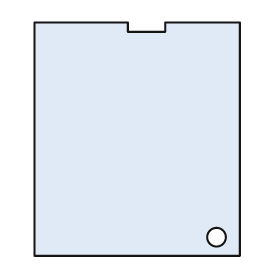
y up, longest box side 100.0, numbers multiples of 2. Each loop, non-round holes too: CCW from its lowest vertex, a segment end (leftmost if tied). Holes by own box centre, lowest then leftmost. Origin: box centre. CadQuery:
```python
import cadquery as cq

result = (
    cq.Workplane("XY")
    .moveTo(-44.0, -50.0)
    .lineTo(44.0, -50.0)
    .lineTo(44.0, 50.0)
    .lineTo(12.0, 50.0)
    .lineTo(12.0, 46.0)
    .lineTo(-4.0, 46.0)
    .lineTo(-4.0, 50.0)
    .lineTo(-44.0, 50.0)
    .close()
    .moveTo(34.0, -42.0)
    .circle(4.0)
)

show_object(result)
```